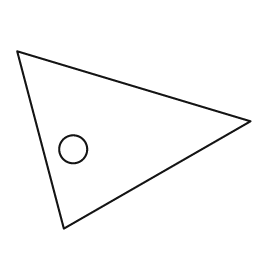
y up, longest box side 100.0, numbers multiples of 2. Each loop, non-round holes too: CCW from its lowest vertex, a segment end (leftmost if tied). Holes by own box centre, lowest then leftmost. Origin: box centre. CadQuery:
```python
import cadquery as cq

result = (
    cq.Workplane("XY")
    .moveTo(-30.0, -38.0)
    .lineTo(50.0, 8.0)
    .lineTo(-50.0, 38.0)
    .close()
    .moveTo(-26.0, -4.0)
    .circle(6.0)
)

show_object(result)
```